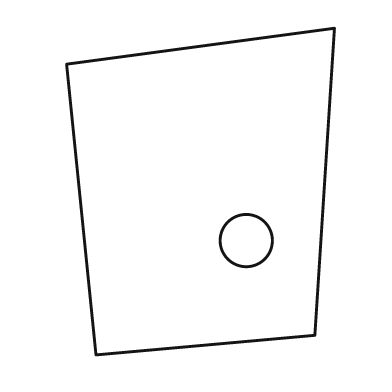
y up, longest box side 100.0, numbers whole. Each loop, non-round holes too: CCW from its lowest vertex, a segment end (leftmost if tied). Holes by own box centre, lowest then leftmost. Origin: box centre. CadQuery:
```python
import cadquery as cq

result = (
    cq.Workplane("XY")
    .moveTo(-32.0, -50.0)
    .lineTo(35.0, -44.0)
    .lineTo(41.0, 50.0)
    .lineTo(-41.0, 39.0)
    .close()
    .moveTo(14.0, -15.0)
    .circle(8.0)
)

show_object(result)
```